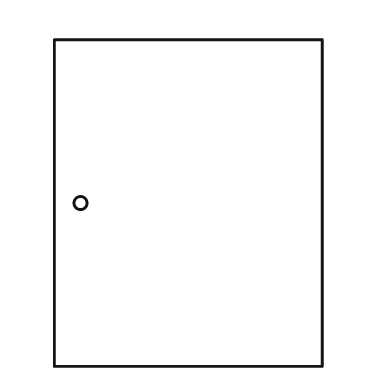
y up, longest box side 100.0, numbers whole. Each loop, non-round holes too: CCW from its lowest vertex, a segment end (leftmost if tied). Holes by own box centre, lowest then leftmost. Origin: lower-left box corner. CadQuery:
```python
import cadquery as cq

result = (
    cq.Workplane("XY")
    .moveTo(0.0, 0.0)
    .lineTo(82.0, 0.0)
    .lineTo(82.0, 100.0)
    .lineTo(0.0, 100.0)
    .close()
    .moveTo(8.0, 50.0)
    .circle(2.0)
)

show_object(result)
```